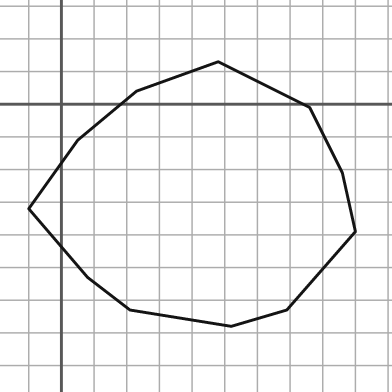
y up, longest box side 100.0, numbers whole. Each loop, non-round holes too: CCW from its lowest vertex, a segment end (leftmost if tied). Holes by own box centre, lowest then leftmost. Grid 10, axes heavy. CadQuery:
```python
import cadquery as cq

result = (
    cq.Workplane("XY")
    .moveTo(52.0, -68.0)
    .lineTo(69.0, -63.0)
    .lineTo(90.0, -39.0)
    .lineTo(86.0, -21.0)
    .lineTo(76.0, -1.0)
    .lineTo(48.0, 13.0)
    .lineTo(23.0, 4.0)
    .lineTo(5.0, -11.0)
    .lineTo(-10.0, -32.0)
    .lineTo(8.0, -53.0)
    .lineTo(21.0, -63.0)
    .close()
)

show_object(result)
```